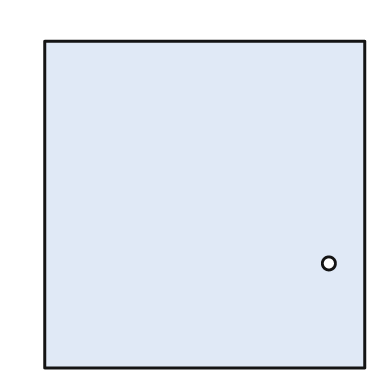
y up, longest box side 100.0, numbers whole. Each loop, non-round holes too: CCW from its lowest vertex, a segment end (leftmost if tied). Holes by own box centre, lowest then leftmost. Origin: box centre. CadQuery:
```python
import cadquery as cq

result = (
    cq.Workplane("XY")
    .moveTo(-49.0, -50.0)
    .lineTo(49.0, -50.0)
    .lineTo(49.0, 50.0)
    .lineTo(-49.0, 50.0)
    .close()
    .moveTo(38.0, -18.0)
    .circle(2.0)
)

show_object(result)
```